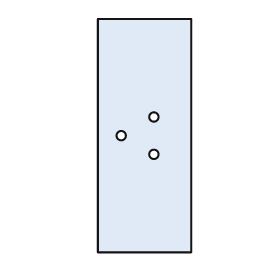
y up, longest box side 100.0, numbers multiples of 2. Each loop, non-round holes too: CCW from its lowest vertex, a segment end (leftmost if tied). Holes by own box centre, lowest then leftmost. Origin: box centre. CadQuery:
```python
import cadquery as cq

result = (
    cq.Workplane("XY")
    .moveTo(-20.0, -50.0)
    .lineTo(20.0, -50.0)
    .lineTo(20.0, 50.0)
    .lineTo(-20.0, 50.0)
    .close()
    .moveTo(4.0, -8.0)
    .circle(2.0)
    .moveTo(-10.0, 0.0)
    .circle(2.0)
    .moveTo(4.0, 8.0)
    .circle(2.0)
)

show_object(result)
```